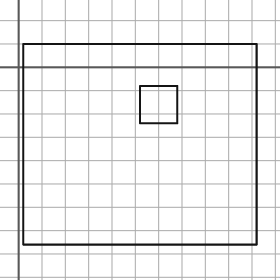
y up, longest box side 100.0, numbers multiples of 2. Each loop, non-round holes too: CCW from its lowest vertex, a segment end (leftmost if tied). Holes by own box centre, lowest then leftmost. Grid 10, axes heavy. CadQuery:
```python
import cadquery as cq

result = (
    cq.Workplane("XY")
    .moveTo(2.0, -76.0)
    .lineTo(102.0, -76.0)
    .lineTo(102.0, 10.0)
    .lineTo(2.0, 10.0)
    .close()
    .moveTo(52.0, -24.0)
    .lineTo(68.0, -24.0)
    .lineTo(68.0, -8.0)
    .lineTo(52.0, -8.0)
    .close()
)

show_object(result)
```